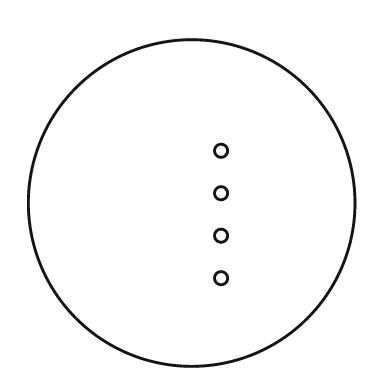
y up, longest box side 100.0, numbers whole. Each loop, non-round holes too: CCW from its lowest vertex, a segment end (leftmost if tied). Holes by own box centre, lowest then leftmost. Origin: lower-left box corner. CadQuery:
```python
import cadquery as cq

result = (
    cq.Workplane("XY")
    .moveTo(50.0, 50.0)
    .circle(50.0)
    .moveTo(59.0, 27.0)
    .circle(2.0)
    .moveTo(59.0, 40.0)
    .circle(2.0)
    .moveTo(59.0, 53.0)
    .circle(2.0)
    .moveTo(59.0, 66.0)
    .circle(2.0)
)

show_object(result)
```